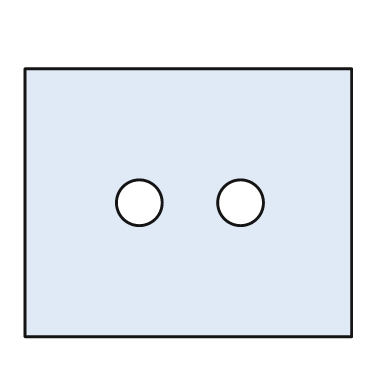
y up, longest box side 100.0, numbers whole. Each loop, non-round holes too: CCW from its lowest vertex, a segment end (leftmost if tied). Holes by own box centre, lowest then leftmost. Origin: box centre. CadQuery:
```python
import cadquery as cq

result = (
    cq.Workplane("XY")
    .moveTo(-50.0, -41.0)
    .lineTo(50.0, -41.0)
    .lineTo(50.0, 41.0)
    .lineTo(-50.0, 41.0)
    .close()
    .moveTo(-15.0, 0.0)
    .circle(7.0)
    .moveTo(16.0, 0.0)
    .circle(7.0)
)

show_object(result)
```